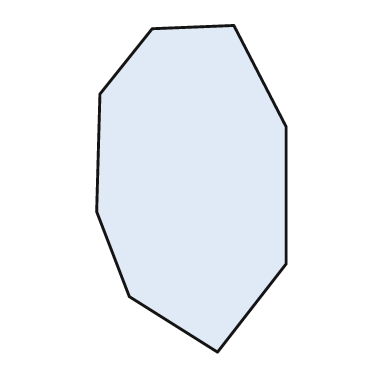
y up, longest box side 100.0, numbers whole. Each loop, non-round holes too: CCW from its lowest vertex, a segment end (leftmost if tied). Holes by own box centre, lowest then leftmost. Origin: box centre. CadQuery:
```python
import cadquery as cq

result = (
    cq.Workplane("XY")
    .moveTo(8.0, -50.0)
    .lineTo(29.0, -23.0)
    .lineTo(29.0, 19.0)
    .lineTo(13.0, 50.0)
    .lineTo(-12.0, 49.0)
    .lineTo(-28.0, 29.0)
    .lineTo(-29.0, -7.0)
    .lineTo(-19.0, -33.0)
    .close()
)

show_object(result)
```